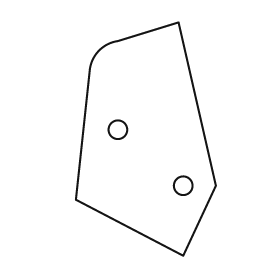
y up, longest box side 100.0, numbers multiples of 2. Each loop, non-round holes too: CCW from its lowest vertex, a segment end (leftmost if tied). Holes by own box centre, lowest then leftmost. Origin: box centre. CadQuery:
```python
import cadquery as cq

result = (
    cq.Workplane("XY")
    .moveTo(16.0, -50.0)
    .lineTo(30.0, -20.0)
    .lineTo(14.0, 50.0)
    .lineTo(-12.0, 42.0)
    .threePointArc((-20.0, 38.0), (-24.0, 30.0))
    .lineTo(-30.0, -26.0)
    .close()
    .moveTo(16.0, -20.0)
    .circle(4.0)
    .moveTo(-12.0, 4.0)
    .circle(4.0)
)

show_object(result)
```